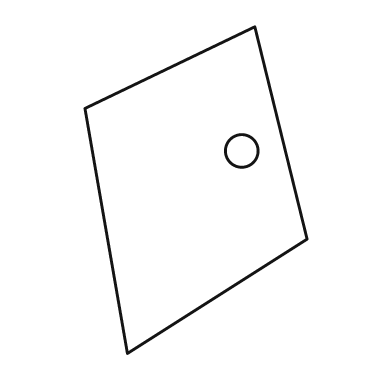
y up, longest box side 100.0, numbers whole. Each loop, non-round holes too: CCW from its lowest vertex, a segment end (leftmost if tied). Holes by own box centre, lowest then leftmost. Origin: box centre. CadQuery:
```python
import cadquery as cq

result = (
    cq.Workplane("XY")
    .moveTo(-21.0, -50.0)
    .lineTo(34.0, -15.0)
    .lineTo(18.0, 50.0)
    .lineTo(-34.0, 25.0)
    .close()
    .moveTo(14.0, 12.0)
    .circle(5.0)
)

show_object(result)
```